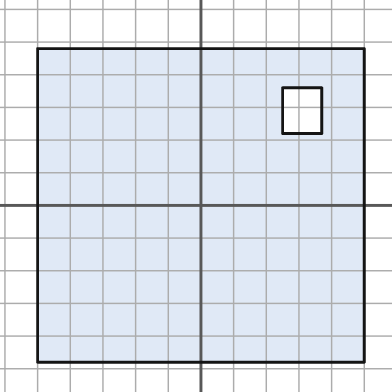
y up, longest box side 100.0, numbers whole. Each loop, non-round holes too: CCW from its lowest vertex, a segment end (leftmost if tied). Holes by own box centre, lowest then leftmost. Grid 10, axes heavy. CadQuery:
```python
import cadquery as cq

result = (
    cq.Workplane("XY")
    .moveTo(-50.0, -48.0)
    .lineTo(50.0, -48.0)
    .lineTo(50.0, 48.0)
    .lineTo(-50.0, 48.0)
    .close()
    .moveTo(25.0, 22.0)
    .lineTo(37.0, 22.0)
    .lineTo(37.0, 36.0)
    .lineTo(25.0, 36.0)
    .close()
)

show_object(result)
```